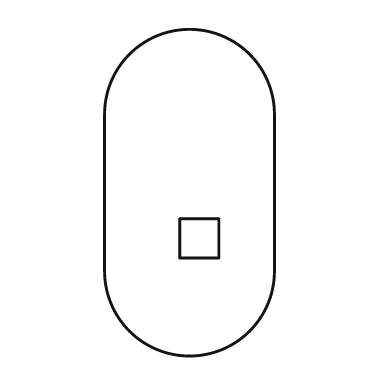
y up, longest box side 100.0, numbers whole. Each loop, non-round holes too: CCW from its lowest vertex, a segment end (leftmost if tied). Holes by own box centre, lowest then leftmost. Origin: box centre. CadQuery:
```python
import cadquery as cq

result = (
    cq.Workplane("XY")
    .moveTo(-26.0, -24.0)
    .threePointArc((0.0, -50.0), (26.0, -24.0))
    .lineTo(26.0, 24.0)
    .threePointArc((0.0, 50.0), (-26.0, 24.0))
    .close()
    .moveTo(-3.0, -20.0)
    .lineTo(9.0, -20.0)
    .lineTo(9.0, -8.0)
    .lineTo(-3.0, -8.0)
    .close()
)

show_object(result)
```